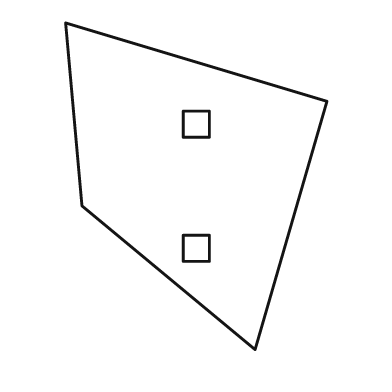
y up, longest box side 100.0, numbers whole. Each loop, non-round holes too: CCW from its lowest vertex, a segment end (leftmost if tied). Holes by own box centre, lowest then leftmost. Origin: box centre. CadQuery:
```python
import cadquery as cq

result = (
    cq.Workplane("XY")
    .moveTo(18.0, -50.0)
    .lineTo(40.0, 26.0)
    .lineTo(-40.0, 50.0)
    .lineTo(-35.0, -6.0)
    .close()
    .moveTo(-4.0, -23.0)
    .lineTo(4.0, -23.0)
    .lineTo(4.0, -15.0)
    .lineTo(-4.0, -15.0)
    .close()
    .moveTo(-4.0, 15.0)
    .lineTo(4.0, 15.0)
    .lineTo(4.0, 23.0)
    .lineTo(-4.0, 23.0)
    .close()
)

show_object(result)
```